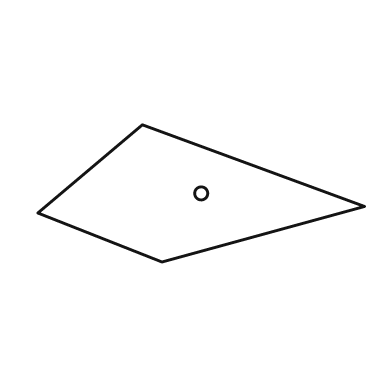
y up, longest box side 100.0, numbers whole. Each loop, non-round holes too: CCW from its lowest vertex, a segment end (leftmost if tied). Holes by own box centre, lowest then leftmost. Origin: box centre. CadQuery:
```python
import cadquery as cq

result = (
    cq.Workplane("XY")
    .moveTo(-12.0, -21.0)
    .lineTo(50.0, -4.0)
    .lineTo(-18.0, 21.0)
    .lineTo(-50.0, -6.0)
    .close()
    .moveTo(0.0, 0.0)
    .circle(2.0)
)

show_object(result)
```